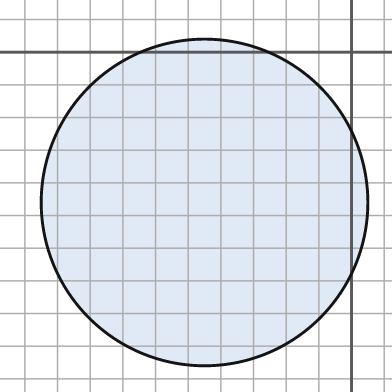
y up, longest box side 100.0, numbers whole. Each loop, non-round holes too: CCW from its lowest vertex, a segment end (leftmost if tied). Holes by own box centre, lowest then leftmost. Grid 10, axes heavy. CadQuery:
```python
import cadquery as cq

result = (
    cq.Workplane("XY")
    .moveTo(-45.0, -46.0)
    .circle(50.0)
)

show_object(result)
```